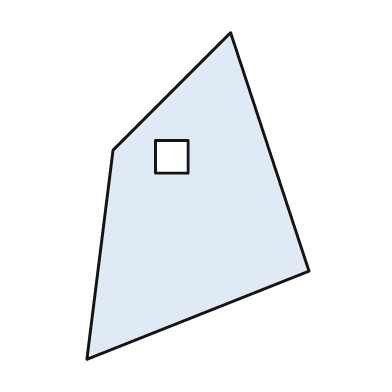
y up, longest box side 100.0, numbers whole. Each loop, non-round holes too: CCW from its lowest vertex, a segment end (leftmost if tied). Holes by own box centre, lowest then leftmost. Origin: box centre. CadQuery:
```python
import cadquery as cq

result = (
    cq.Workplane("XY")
    .moveTo(-34.0, -50.0)
    .lineTo(34.0, -23.0)
    .lineTo(10.0, 50.0)
    .lineTo(-26.0, 14.0)
    .close()
    .moveTo(-13.0, 7.0)
    .lineTo(-3.0, 7.0)
    .lineTo(-3.0, 17.0)
    .lineTo(-13.0, 17.0)
    .close()
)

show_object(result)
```